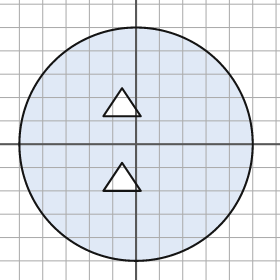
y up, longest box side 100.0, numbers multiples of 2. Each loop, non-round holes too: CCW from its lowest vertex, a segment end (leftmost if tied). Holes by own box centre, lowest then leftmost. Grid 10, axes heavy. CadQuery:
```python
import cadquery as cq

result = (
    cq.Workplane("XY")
    .moveTo(0.0, 0.0)
    .circle(50.0)
    .moveTo(-14.0, -20.0)
    .lineTo(2.0, -20.0)
    .lineTo(-6.0, -8.0)
    .close()
    .moveTo(-14.0, 12.0)
    .lineTo(2.0, 12.0)
    .lineTo(-6.0, 24.0)
    .close()
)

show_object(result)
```